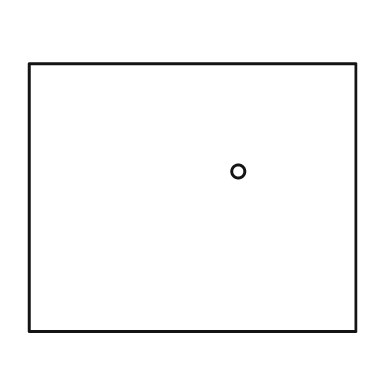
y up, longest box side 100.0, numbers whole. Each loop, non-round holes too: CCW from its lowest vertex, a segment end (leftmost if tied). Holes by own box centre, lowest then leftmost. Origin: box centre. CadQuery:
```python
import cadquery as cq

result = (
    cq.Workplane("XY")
    .moveTo(-50.0, -41.0)
    .lineTo(50.0, -41.0)
    .lineTo(50.0, 41.0)
    .lineTo(-50.0, 41.0)
    .close()
    .moveTo(14.0, 8.0)
    .circle(2.0)
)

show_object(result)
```